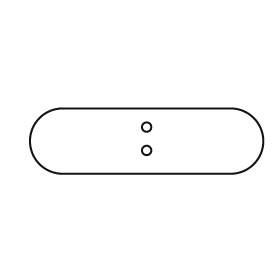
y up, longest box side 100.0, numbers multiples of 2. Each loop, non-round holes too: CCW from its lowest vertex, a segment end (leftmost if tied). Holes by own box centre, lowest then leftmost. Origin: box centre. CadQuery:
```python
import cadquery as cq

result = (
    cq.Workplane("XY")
    .moveTo(-36.0, -14.0)
    .lineTo(36.0, -14.0)
    .threePointArc((50.0, 0.0), (36.0, 14.0))
    .lineTo(-36.0, 14.0)
    .threePointArc((-50.0, 0.0), (-36.0, -14.0))
    .close()
    .moveTo(0.0, -4.0)
    .circle(2.0)
    .moveTo(0.0, 6.0)
    .circle(2.0)
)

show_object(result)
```